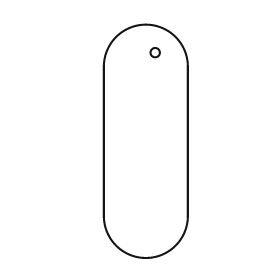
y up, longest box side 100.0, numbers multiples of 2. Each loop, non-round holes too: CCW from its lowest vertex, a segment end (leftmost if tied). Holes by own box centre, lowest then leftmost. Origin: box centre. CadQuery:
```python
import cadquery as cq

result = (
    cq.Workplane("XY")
    .moveTo(-18.0, -32.0)
    .threePointArc((0.0, -50.0), (18.0, -32.0))
    .lineTo(18.0, 32.0)
    .threePointArc((0.0, 50.0), (-18.0, 32.0))
    .close()
    .moveTo(4.0, 38.0)
    .circle(2.0)
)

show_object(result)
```